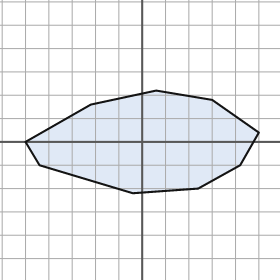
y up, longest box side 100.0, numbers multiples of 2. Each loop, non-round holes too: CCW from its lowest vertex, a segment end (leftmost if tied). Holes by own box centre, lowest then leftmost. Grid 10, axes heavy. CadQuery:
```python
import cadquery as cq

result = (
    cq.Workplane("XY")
    .moveTo(-4.0, -22.0)
    .lineTo(24.0, -20.0)
    .lineTo(42.0, -10.0)
    .lineTo(50.0, 4.0)
    .lineTo(30.0, 18.0)
    .lineTo(6.0, 22.0)
    .lineTo(-22.0, 16.0)
    .lineTo(-50.0, 0.0)
    .lineTo(-44.0, -10.0)
    .close()
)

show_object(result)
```